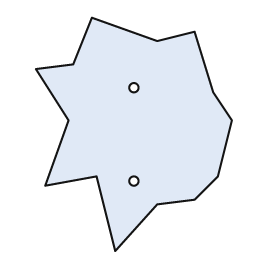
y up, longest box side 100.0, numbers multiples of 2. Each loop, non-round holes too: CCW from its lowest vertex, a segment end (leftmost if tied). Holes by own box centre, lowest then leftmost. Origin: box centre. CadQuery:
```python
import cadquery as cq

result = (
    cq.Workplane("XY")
    .moveTo(-8.0, -50.0)
    .lineTo(10.0, -30.0)
    .lineTo(26.0, -28.0)
    .lineTo(36.0, -18.0)
    .lineTo(42.0, 6.0)
    .lineTo(34.0, 18.0)
    .lineTo(26.0, 44.0)
    .lineTo(10.0, 40.0)
    .lineTo(-18.0, 50.0)
    .lineTo(-26.0, 30.0)
    .lineTo(-42.0, 28.0)
    .lineTo(-28.0, 6.0)
    .lineTo(-38.0, -22.0)
    .lineTo(-16.0, -18.0)
    .close()
    .moveTo(0.0, -20.0)
    .circle(2.0)
    .moveTo(0.0, 20.0)
    .circle(2.0)
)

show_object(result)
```